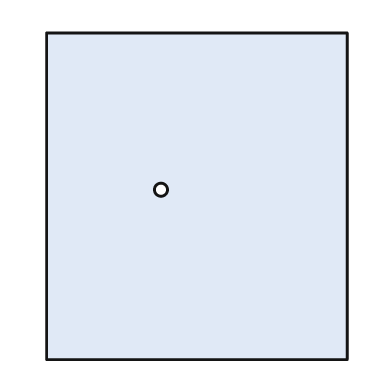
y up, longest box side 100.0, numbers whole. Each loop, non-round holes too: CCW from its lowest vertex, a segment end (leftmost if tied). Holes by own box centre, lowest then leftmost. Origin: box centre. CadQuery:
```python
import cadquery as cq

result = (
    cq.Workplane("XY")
    .moveTo(-46.0, -50.0)
    .lineTo(46.0, -50.0)
    .lineTo(46.0, 50.0)
    .lineTo(-46.0, 50.0)
    .close()
    .moveTo(-11.0, 2.0)
    .circle(2.0)
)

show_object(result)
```